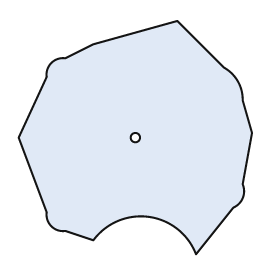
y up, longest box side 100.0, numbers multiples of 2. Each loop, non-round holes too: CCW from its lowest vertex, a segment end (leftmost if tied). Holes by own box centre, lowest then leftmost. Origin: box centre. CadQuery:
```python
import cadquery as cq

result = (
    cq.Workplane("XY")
    .moveTo(26.0, -50.0)
    .lineTo(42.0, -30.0)
    .threePointArc((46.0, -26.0), (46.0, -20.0))
    .lineTo(50.0, 2.0)
    .lineTo(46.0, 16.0)
    .threePointArc((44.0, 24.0), (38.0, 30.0))
    .lineTo(18.0, 50.0)
    .lineTo(-18.0, 40.0)
    .lineTo(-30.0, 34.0)
    .threePointArc((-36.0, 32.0), (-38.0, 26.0))
    .lineTo(-50.0, 0.0)
    .lineTo(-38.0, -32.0)
    .threePointArc((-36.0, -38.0), (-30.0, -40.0))
    .lineTo(-18.0, -44.0)
    .threePointArc((6.0, -34.0), (26.0, -50.0))
    .close()
    .moveTo(0.0, 0.0)
    .circle(2.0)
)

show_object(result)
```